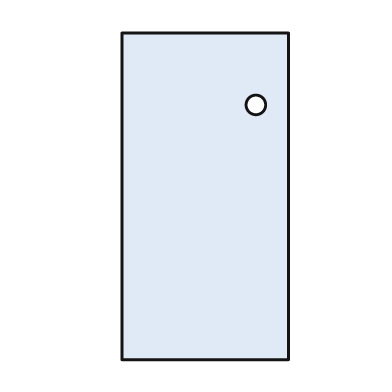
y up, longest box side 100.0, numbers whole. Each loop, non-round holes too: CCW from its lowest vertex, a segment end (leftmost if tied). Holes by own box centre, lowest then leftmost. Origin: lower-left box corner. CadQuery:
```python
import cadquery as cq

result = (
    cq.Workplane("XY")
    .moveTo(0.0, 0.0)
    .lineTo(51.0, 0.0)
    .lineTo(51.0, 100.0)
    .lineTo(0.0, 100.0)
    .close()
    .moveTo(41.0, 78.0)
    .circle(3.0)
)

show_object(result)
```